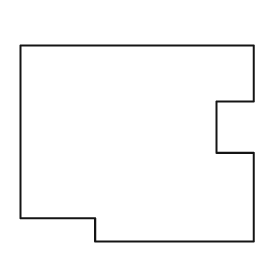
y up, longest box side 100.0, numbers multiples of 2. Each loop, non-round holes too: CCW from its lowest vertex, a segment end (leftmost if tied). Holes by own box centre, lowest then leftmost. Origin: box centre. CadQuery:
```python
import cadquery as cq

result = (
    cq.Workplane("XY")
    .moveTo(-18.0, -42.0)
    .lineTo(50.0, -42.0)
    .lineTo(50.0, -4.0)
    .lineTo(34.0, -4.0)
    .lineTo(34.0, 18.0)
    .lineTo(50.0, 18.0)
    .lineTo(50.0, 42.0)
    .lineTo(-50.0, 42.0)
    .lineTo(-50.0, -32.0)
    .lineTo(-18.0, -32.0)
    .close()
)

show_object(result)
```